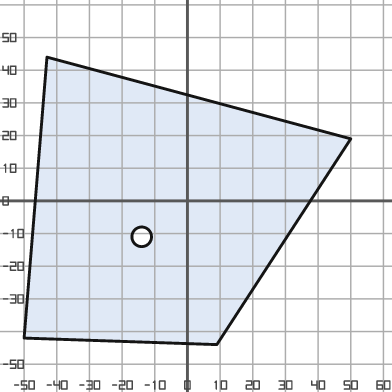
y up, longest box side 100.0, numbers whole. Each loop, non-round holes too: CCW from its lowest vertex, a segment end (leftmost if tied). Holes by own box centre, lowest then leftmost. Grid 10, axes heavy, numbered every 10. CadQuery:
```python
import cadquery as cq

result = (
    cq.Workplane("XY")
    .moveTo(9.0, -44.0)
    .lineTo(50.0, 19.0)
    .lineTo(-43.0, 44.0)
    .lineTo(-50.0, -42.0)
    .close()
    .moveTo(-14.0, -11.0)
    .circle(3.0)
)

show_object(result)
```